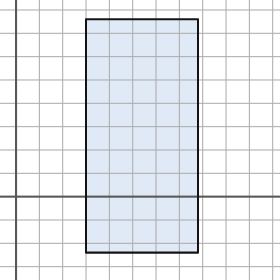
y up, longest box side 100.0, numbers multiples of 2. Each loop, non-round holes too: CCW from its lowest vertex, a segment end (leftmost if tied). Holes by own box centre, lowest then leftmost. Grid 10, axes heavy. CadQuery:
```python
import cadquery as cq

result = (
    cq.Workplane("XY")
    .moveTo(30.0, -24.0)
    .lineTo(78.0, -24.0)
    .lineTo(78.0, 76.0)
    .lineTo(30.0, 76.0)
    .close()
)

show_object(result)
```